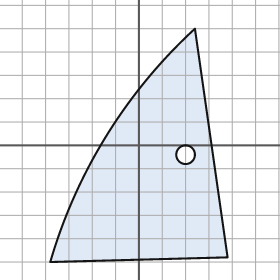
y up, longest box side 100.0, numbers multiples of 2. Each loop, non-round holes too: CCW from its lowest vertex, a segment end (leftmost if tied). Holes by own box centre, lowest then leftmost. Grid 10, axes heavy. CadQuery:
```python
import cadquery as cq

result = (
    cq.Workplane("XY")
    .moveTo(-38.0, -50.0)
    .lineTo(38.0, -48.0)
    .lineTo(24.0, 50.0)
    .threePointArc((-14.0, 4.0), (-38.0, -50.0))
    .close()
    .moveTo(20.0, -4.0)
    .circle(4.0)
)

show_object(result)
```